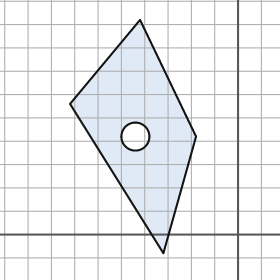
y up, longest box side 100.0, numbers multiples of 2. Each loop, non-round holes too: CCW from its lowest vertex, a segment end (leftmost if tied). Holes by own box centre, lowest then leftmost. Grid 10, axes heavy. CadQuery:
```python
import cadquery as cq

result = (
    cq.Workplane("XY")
    .moveTo(-32.0, -8.0)
    .lineTo(-18.0, 42.0)
    .lineTo(-42.0, 92.0)
    .lineTo(-72.0, 56.0)
    .close()
    .moveTo(-44.0, 42.0)
    .circle(6.0)
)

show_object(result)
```